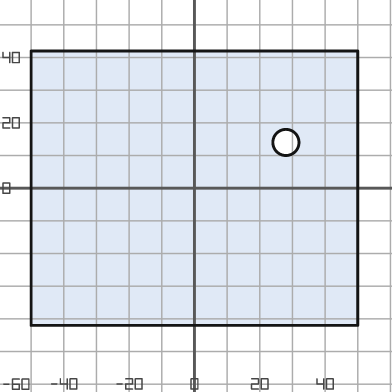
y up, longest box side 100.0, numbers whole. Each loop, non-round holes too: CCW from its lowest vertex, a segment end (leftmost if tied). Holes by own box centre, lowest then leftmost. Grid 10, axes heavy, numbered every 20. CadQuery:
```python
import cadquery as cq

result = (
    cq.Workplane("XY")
    .moveTo(-50.0, -42.0)
    .lineTo(50.0, -42.0)
    .lineTo(50.0, 42.0)
    .lineTo(-50.0, 42.0)
    .close()
    .moveTo(28.0, 14.0)
    .circle(4.0)
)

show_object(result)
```